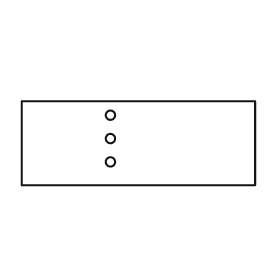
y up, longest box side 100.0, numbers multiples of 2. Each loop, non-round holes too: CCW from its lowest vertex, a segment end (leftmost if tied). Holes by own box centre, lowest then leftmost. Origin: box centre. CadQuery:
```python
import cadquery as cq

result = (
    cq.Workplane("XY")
    .moveTo(-50.0, -18.0)
    .lineTo(50.0, -18.0)
    .lineTo(50.0, 18.0)
    .lineTo(-50.0, 18.0)
    .close()
    .moveTo(-12.0, -8.0)
    .circle(2.0)
    .moveTo(-12.0, 2.0)
    .circle(2.0)
    .moveTo(-12.0, 12.0)
    .circle(2.0)
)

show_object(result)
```